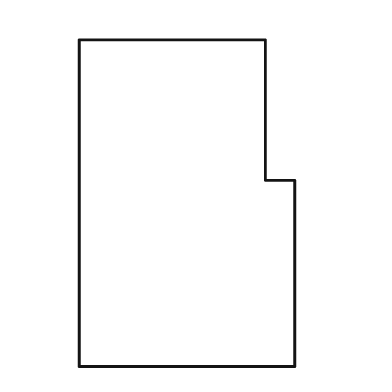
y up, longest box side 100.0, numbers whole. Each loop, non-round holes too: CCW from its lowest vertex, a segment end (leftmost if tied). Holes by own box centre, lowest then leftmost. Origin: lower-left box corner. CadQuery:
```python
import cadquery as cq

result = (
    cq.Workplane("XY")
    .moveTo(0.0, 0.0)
    .lineTo(66.0, 0.0)
    .lineTo(66.0, 57.0)
    .lineTo(57.0, 57.0)
    .lineTo(57.0, 100.0)
    .lineTo(0.0, 100.0)
    .close()
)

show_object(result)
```